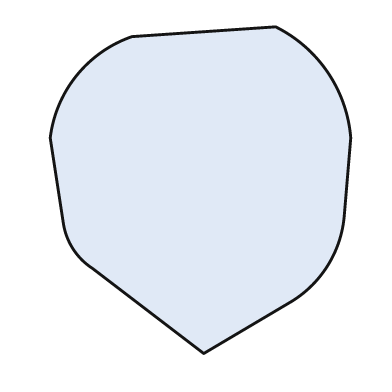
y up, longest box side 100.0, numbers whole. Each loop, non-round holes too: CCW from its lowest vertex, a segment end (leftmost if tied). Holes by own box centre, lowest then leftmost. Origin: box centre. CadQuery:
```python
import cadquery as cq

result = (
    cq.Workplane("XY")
    .moveTo(1.0, -50.0)
    .lineTo(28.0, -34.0)
    .threePointArc((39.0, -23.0), (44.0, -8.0))
    .lineTo(46.0, 16.0)
    .threePointArc((39.0, 36.0), (23.0, 50.0))
    .lineTo(-21.0, 47.0)
    .threePointArc((-38.0, 35.0), (-46.0, 16.0))
    .lineTo(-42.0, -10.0)
    .threePointArc((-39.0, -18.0), (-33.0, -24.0))
    .close()
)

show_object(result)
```